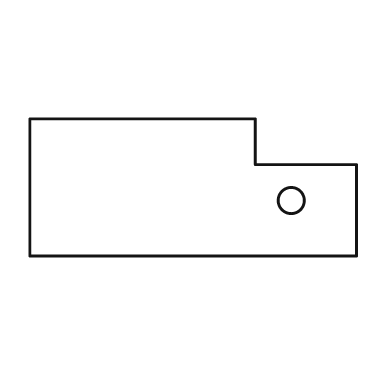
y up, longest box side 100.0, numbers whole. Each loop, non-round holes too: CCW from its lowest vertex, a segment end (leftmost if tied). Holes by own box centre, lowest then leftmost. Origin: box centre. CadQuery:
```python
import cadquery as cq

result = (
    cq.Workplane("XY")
    .moveTo(-50.0, -21.0)
    .lineTo(50.0, -21.0)
    .lineTo(50.0, 7.0)
    .lineTo(19.0, 7.0)
    .lineTo(19.0, 21.0)
    .lineTo(-50.0, 21.0)
    .close()
    .moveTo(30.0, -4.0)
    .circle(4.0)
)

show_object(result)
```